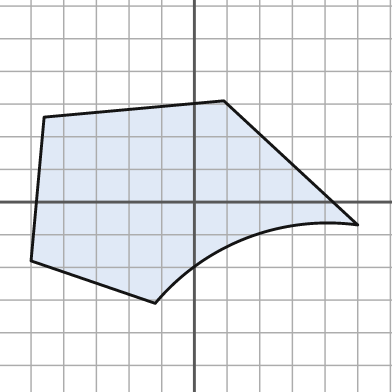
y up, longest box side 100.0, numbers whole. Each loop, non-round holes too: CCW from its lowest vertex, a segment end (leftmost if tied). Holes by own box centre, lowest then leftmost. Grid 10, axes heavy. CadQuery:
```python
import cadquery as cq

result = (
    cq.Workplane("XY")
    .moveTo(-12.0, -31.0)
    .threePointArc((16.0, -11.0), (50.0, -7.0))
    .lineTo(9.0, 31.0)
    .lineTo(-46.0, 26.0)
    .lineTo(-50.0, -18.0)
    .close()
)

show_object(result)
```